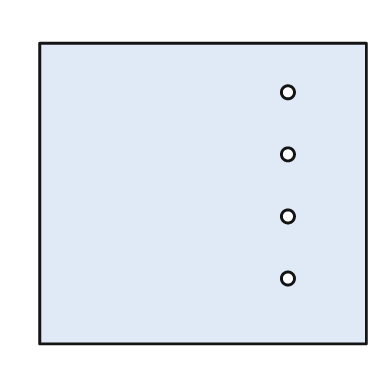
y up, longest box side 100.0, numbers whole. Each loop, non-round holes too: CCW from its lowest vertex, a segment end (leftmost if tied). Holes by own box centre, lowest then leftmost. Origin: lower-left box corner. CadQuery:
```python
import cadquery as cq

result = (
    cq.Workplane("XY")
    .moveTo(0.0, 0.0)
    .lineTo(100.0, 0.0)
    .lineTo(100.0, 92.0)
    .lineTo(0.0, 92.0)
    .close()
    .moveTo(76.0, 20.0)
    .circle(2.0)
    .moveTo(76.0, 39.0)
    .circle(2.0)
    .moveTo(76.0, 58.0)
    .circle(2.0)
    .moveTo(76.0, 77.0)
    .circle(2.0)
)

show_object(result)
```